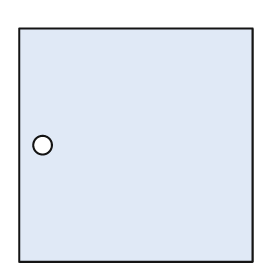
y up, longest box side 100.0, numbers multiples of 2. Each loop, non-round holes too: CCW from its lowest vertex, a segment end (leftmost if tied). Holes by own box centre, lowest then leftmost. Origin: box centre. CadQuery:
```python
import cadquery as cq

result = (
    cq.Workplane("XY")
    .moveTo(-50.0, -50.0)
    .lineTo(50.0, -50.0)
    .lineTo(50.0, 50.0)
    .lineTo(-50.0, 50.0)
    .close()
    .moveTo(-40.0, 0.0)
    .circle(4.0)
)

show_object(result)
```